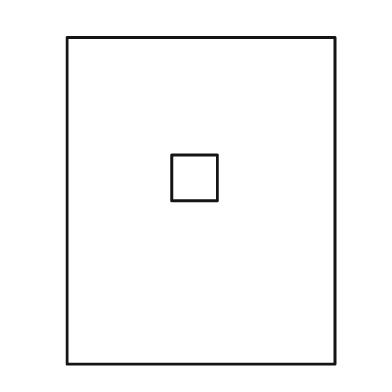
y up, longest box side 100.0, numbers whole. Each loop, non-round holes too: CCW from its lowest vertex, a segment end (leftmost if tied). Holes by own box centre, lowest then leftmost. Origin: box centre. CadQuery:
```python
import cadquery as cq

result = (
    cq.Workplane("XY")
    .moveTo(-41.0, -50.0)
    .lineTo(41.0, -50.0)
    .lineTo(41.0, 50.0)
    .lineTo(-41.0, 50.0)
    .close()
    .moveTo(-9.0, 0.0)
    .lineTo(5.0, 0.0)
    .lineTo(5.0, 14.0)
    .lineTo(-9.0, 14.0)
    .close()
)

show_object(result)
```